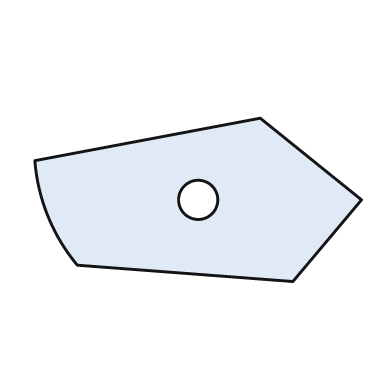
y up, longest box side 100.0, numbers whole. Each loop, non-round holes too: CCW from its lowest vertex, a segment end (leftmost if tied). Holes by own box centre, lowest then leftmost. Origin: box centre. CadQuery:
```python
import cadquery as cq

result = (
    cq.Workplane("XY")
    .moveTo(29.0, -25.0)
    .lineTo(50.0, 0.0)
    .lineTo(19.0, 25.0)
    .lineTo(-50.0, 12.0)
    .threePointArc((-46.0, -5.0), (-37.0, -20.0))
    .close()
    .moveTo(0.0, 0.0)
    .circle(6.0)
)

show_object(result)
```